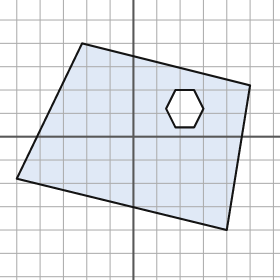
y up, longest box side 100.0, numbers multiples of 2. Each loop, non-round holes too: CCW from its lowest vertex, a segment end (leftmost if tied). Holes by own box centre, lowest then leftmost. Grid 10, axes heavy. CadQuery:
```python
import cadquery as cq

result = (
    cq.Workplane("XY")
    .moveTo(40.0, -40.0)
    .lineTo(50.0, 22.0)
    .lineTo(-22.0, 40.0)
    .lineTo(-50.0, -18.0)
    .close()
    .moveTo(18.0, 4.0)
    .lineTo(26.0, 4.0)
    .lineTo(30.0, 12.0)
    .lineTo(26.0, 20.0)
    .lineTo(18.0, 20.0)
    .lineTo(14.0, 12.0)
    .close()
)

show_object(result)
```